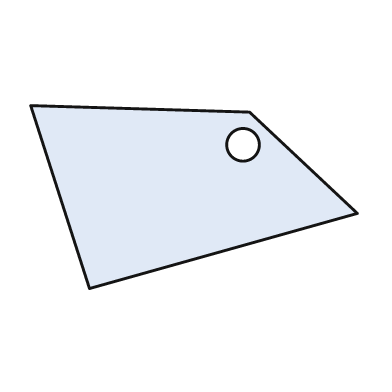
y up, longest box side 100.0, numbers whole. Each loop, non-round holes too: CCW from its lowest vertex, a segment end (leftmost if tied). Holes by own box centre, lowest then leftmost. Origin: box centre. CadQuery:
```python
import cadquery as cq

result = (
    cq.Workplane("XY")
    .moveTo(-32.0, -28.0)
    .lineTo(50.0, -5.0)
    .lineTo(17.0, 26.0)
    .lineTo(-50.0, 28.0)
    .close()
    .moveTo(15.0, 16.0)
    .circle(5.0)
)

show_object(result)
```